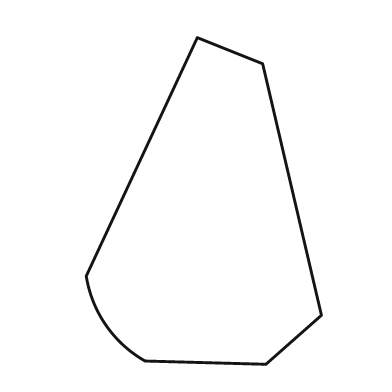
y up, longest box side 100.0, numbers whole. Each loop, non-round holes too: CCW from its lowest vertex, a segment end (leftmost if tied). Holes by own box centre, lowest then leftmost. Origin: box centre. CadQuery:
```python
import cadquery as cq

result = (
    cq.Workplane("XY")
    .moveTo(19.0, -50.0)
    .lineTo(36.0, -35.0)
    .lineTo(18.0, 42.0)
    .lineTo(-2.0, 50.0)
    .lineTo(-36.0, -23.0)
    .threePointArc((-30.0, -38.0), (-18.0, -49.0))
    .close()
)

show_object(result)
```